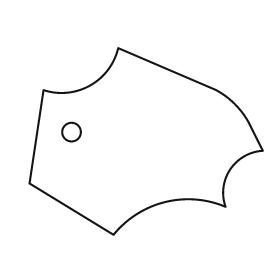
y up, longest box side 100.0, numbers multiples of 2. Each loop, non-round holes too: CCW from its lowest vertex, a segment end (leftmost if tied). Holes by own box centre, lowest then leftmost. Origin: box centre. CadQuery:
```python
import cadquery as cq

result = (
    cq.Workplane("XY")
    .moveTo(-14.0, -40.0)
    .threePointArc((8.0, -26.0), (34.0, -28.0))
    .threePointArc((36.0, -12.0), (50.0, -4.0))
    .lineTo(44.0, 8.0)
    .threePointArc((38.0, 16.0), (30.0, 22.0))
    .lineTo(-12.0, 40.0)
    .threePointArc((-24.0, 24.0), (-44.0, 22.0))
    .lineTo(-50.0, -18.0)
    .close()
    .moveTo(-32.0, 4.0)
    .circle(4.0)
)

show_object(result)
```